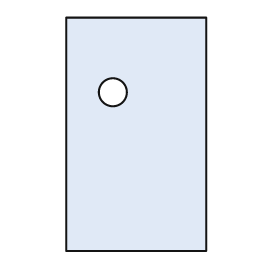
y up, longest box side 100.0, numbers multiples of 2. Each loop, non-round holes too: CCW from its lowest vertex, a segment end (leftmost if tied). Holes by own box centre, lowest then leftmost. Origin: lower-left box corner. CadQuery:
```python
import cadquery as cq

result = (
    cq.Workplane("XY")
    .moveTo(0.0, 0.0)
    .lineTo(60.0, 0.0)
    .lineTo(60.0, 100.0)
    .lineTo(0.0, 100.0)
    .close()
    .moveTo(20.0, 68.0)
    .circle(6.0)
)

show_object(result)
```